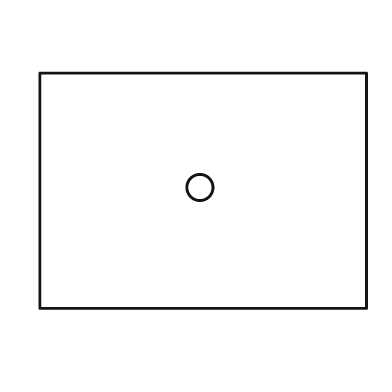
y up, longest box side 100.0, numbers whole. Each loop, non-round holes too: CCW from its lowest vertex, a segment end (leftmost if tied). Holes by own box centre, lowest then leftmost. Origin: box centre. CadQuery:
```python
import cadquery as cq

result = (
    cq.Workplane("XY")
    .moveTo(-50.0, -36.0)
    .lineTo(50.0, -36.0)
    .lineTo(50.0, 36.0)
    .lineTo(-50.0, 36.0)
    .close()
    .moveTo(-1.0, 1.0)
    .circle(4.0)
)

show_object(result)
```